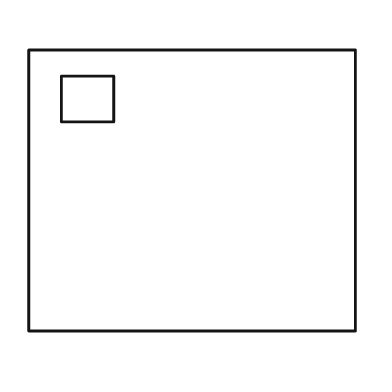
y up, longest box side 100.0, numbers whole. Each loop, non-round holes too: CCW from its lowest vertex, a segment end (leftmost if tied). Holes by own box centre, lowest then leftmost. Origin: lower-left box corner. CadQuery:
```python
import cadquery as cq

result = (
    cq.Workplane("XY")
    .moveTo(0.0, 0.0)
    .lineTo(100.0, 0.0)
    .lineTo(100.0, 86.0)
    .lineTo(0.0, 86.0)
    .close()
    .moveTo(10.0, 64.0)
    .lineTo(26.0, 64.0)
    .lineTo(26.0, 78.0)
    .lineTo(10.0, 78.0)
    .close()
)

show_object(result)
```